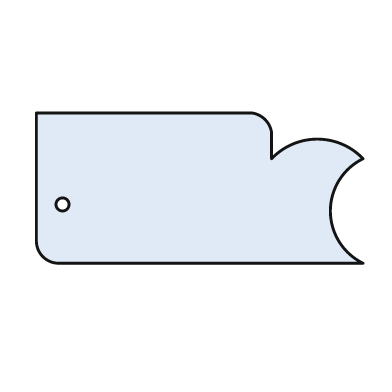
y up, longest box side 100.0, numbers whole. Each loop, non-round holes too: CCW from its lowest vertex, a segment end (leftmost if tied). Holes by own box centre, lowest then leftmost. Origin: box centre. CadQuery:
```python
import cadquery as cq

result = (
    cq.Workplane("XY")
    .moveTo(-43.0, -23.0)
    .lineTo(50.0, -23.0)
    .threePointArc((40.0, -7.0), (50.0, 9.0))
    .threePointArc((36.0, 15.0), (22.0, 9.0))
    .lineTo(22.0, 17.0)
    .threePointArc((20.0, 21.0), (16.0, 23.0))
    .lineTo(-50.0, 23.0)
    .lineTo(-50.0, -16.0)
    .threePointArc((-48.0, -21.0), (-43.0, -23.0))
    .close()
    .moveTo(-42.0, -5.0)
    .circle(2.0)
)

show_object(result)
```